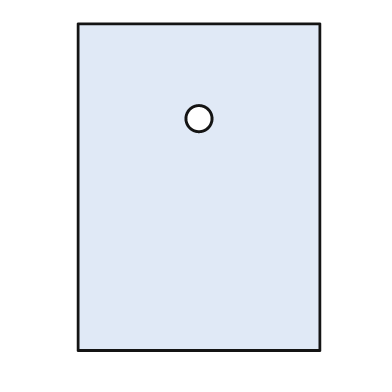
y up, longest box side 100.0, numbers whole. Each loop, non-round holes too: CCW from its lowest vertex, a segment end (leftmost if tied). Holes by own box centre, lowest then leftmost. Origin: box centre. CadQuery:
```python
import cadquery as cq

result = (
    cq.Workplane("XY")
    .moveTo(-37.0, -50.0)
    .lineTo(37.0, -50.0)
    .lineTo(37.0, 50.0)
    .lineTo(-37.0, 50.0)
    .close()
    .moveTo(0.0, 21.0)
    .circle(4.0)
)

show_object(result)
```